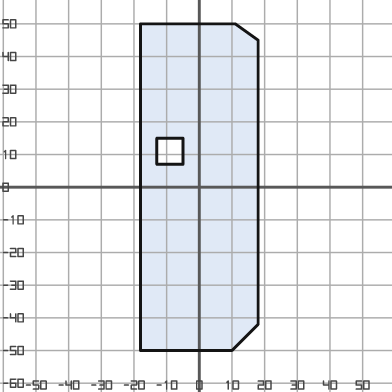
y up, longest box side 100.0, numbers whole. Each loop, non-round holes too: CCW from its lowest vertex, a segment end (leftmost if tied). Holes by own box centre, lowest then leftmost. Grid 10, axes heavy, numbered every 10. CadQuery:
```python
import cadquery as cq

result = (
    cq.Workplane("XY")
    .moveTo(-18.0, -50.0)
    .lineTo(10.0, -50.0)
    .lineTo(18.0, -42.0)
    .lineTo(18.0, 45.0)
    .lineTo(11.0, 50.0)
    .lineTo(-18.0, 50.0)
    .close()
    .moveTo(-13.0, 7.0)
    .lineTo(-5.0, 7.0)
    .lineTo(-5.0, 15.0)
    .lineTo(-13.0, 15.0)
    .close()
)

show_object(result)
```